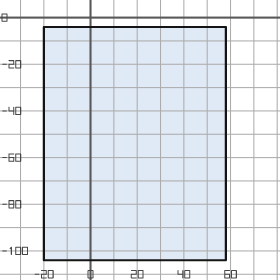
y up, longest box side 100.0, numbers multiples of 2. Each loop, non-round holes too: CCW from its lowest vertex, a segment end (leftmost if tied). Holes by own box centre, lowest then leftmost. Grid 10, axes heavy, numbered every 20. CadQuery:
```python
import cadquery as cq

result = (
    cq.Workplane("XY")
    .moveTo(-20.0, -104.0)
    .lineTo(58.0, -104.0)
    .lineTo(58.0, -4.0)
    .lineTo(-20.0, -4.0)
    .close()
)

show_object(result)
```